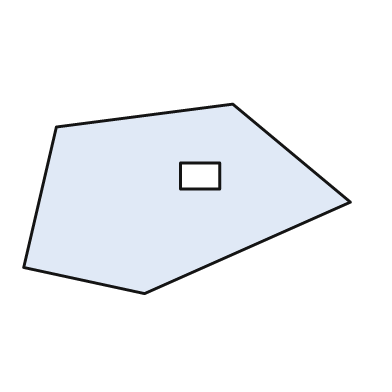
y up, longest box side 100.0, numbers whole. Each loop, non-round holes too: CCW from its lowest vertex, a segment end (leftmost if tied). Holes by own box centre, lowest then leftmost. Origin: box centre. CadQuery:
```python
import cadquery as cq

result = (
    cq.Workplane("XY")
    .moveTo(-13.0, -29.0)
    .lineTo(50.0, -1.0)
    .lineTo(14.0, 29.0)
    .lineTo(-40.0, 22.0)
    .lineTo(-50.0, -21.0)
    .close()
    .moveTo(-2.0, 3.0)
    .lineTo(10.0, 3.0)
    .lineTo(10.0, 11.0)
    .lineTo(-2.0, 11.0)
    .close()
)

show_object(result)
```